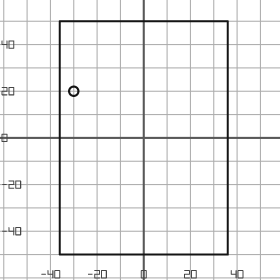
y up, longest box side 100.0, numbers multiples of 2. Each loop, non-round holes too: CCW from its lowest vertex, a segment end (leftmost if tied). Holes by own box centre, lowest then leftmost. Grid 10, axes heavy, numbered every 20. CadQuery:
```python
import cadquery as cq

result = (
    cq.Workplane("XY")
    .moveTo(-36.0, -50.0)
    .lineTo(36.0, -50.0)
    .lineTo(36.0, 50.0)
    .lineTo(-36.0, 50.0)
    .close()
    .moveTo(-30.0, 20.0)
    .circle(2.0)
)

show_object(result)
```